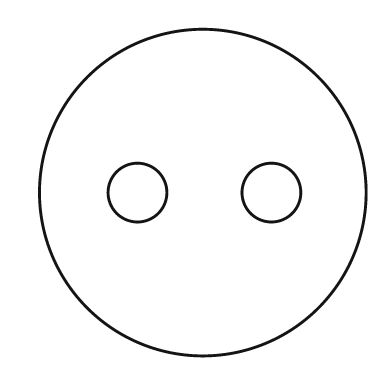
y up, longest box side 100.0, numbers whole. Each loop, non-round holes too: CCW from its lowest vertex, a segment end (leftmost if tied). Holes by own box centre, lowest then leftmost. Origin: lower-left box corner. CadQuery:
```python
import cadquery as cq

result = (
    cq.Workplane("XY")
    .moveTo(50.0, 50.0)
    .circle(50.0)
    .moveTo(30.0, 50.0)
    .circle(9.0)
    .moveTo(71.0, 50.0)
    .circle(9.0)
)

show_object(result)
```